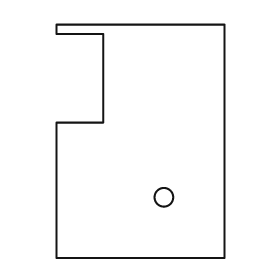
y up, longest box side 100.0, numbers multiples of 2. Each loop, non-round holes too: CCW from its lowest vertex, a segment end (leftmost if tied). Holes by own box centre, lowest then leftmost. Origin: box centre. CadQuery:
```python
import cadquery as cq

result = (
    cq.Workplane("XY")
    .moveTo(-36.0, -50.0)
    .lineTo(36.0, -50.0)
    .lineTo(36.0, 50.0)
    .lineTo(-36.0, 50.0)
    .lineTo(-36.0, 46.0)
    .lineTo(-16.0, 46.0)
    .lineTo(-16.0, 8.0)
    .lineTo(-36.0, 8.0)
    .close()
    .moveTo(10.0, -24.0)
    .circle(4.0)
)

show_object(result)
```